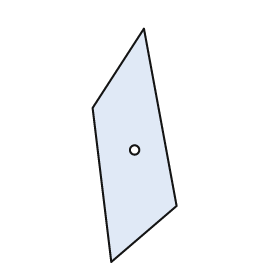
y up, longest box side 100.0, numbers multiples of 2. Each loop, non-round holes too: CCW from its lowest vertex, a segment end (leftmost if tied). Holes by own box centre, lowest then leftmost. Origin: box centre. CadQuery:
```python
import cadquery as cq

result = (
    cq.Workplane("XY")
    .moveTo(-10.0, -50.0)
    .lineTo(18.0, -26.0)
    .lineTo(4.0, 50.0)
    .lineTo(-18.0, 16.0)
    .close()
    .moveTo(0.0, -2.0)
    .circle(2.0)
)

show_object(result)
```